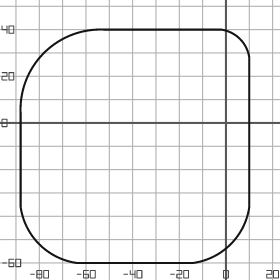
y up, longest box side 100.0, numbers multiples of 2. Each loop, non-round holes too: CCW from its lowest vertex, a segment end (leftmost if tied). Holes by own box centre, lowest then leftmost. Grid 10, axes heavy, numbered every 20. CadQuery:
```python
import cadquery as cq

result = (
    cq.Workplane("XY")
    .moveTo(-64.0, -60.0)
    .lineTo(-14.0, -60.0)
    .threePointArc((2.0, -52.0), (10.0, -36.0))
    .lineTo(10.0, 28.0)
    .threePointArc((6.0, 36.0), (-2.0, 40.0))
    .lineTo(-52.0, 40.0)
    .threePointArc((-78.0, 30.0), (-88.0, 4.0))
    .lineTo(-88.0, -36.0)
    .threePointArc((-80.0, -52.0), (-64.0, -60.0))
    .close()
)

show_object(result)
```